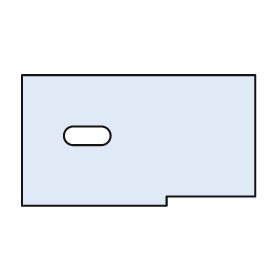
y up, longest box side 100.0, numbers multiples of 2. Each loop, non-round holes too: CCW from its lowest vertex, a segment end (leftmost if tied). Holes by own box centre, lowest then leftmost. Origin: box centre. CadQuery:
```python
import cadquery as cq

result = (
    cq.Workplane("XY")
    .moveTo(-50.0, -28.0)
    .lineTo(12.0, -28.0)
    .lineTo(12.0, -24.0)
    .lineTo(50.0, -24.0)
    .lineTo(50.0, 28.0)
    .lineTo(-50.0, 28.0)
    .close()
    .moveTo(-28.0, -2.0)
    .lineTo(-16.0, -2.0)
    .threePointArc((-12.0, 2.0), (-16.0, 6.0))
    .lineTo(-28.0, 6.0)
    .threePointArc((-32.0, 2.0), (-28.0, -2.0))
    .close()
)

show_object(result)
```